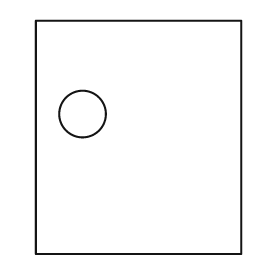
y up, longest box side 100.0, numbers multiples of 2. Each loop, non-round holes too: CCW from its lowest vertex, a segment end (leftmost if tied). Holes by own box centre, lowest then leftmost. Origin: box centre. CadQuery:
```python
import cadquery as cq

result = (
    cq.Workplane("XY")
    .moveTo(-44.0, -50.0)
    .lineTo(44.0, -50.0)
    .lineTo(44.0, 50.0)
    .lineTo(-44.0, 50.0)
    .close()
    .moveTo(-24.0, 10.0)
    .circle(10.0)
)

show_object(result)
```